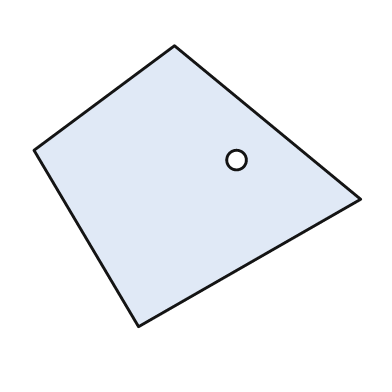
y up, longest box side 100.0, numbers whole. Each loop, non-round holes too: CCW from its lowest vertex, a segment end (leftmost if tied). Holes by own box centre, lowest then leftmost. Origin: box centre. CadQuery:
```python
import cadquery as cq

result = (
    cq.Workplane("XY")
    .moveTo(-18.0, -43.0)
    .lineTo(50.0, -4.0)
    .lineTo(-7.0, 43.0)
    .lineTo(-50.0, 11.0)
    .close()
    .moveTo(12.0, 8.0)
    .circle(3.0)
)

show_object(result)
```